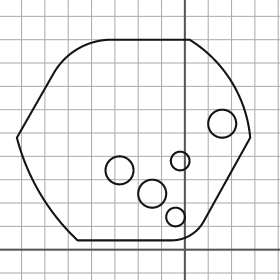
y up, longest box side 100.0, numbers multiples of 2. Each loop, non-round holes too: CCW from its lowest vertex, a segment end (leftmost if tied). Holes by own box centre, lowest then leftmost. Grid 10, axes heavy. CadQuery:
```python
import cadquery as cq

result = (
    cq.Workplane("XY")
    .moveTo(-46.0, 4.0)
    .lineTo(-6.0, 4.0)
    .threePointArc((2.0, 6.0), (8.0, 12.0))
    .lineTo(28.0, 48.0)
    .threePointArc((20.0, 72.0), (2.0, 90.0))
    .lineTo(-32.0, 90.0)
    .threePointArc((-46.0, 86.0), (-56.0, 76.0))
    .lineTo(-72.0, 48.0)
    .threePointArc((-62.0, 24.0), (-46.0, 4.0))
    .close()
    .moveTo(-4.0, 14.0)
    .circle(4.0)
    .moveTo(-14.0, 24.0)
    .circle(6.0)
    .moveTo(-28.0, 34.0)
    .circle(6.0)
    .moveTo(-2.0, 38.0)
    .circle(4.0)
    .moveTo(16.0, 54.0)
    .circle(6.0)
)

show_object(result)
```